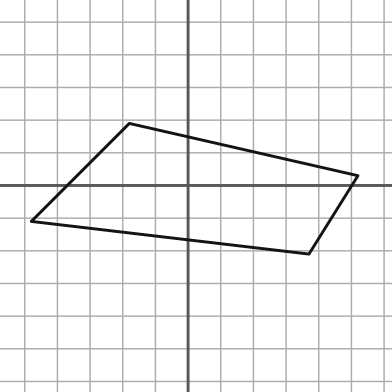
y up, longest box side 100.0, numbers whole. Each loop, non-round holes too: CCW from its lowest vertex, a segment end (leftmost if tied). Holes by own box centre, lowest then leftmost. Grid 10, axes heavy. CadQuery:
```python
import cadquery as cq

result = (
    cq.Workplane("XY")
    .moveTo(37.0, -21.0)
    .lineTo(52.0, 3.0)
    .lineTo(-18.0, 19.0)
    .lineTo(-48.0, -11.0)
    .close()
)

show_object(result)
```